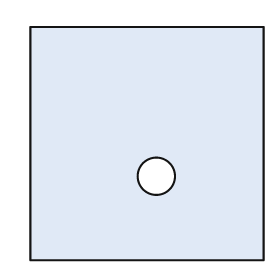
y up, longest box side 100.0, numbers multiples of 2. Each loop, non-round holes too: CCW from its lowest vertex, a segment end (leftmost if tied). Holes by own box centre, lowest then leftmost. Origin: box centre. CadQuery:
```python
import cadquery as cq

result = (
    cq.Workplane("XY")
    .moveTo(-50.0, -50.0)
    .lineTo(50.0, -50.0)
    .lineTo(50.0, 50.0)
    .lineTo(-50.0, 50.0)
    .close()
    .moveTo(4.0, -14.0)
    .circle(8.0)
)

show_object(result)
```